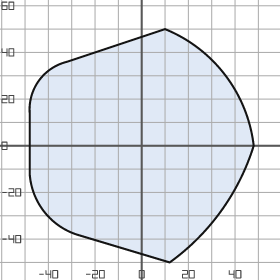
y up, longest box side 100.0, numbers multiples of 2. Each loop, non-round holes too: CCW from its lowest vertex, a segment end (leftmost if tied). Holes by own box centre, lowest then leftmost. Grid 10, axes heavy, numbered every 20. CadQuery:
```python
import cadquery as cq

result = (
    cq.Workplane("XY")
    .moveTo(12.0, -50.0)
    .threePointArc((34.0, -28.0), (48.0, 0.0))
    .threePointArc((36.0, 30.0), (10.0, 50.0))
    .lineTo(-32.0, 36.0)
    .threePointArc((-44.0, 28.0), (-48.0, 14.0))
    .lineTo(-48.0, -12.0)
    .threePointArc((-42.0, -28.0), (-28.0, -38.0))
    .close()
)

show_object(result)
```